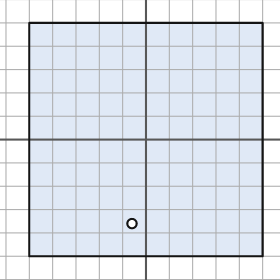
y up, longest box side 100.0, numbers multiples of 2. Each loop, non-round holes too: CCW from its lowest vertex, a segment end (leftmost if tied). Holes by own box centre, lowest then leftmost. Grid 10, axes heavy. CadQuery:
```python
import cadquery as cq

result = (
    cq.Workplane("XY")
    .moveTo(-50.0, -50.0)
    .lineTo(50.0, -50.0)
    .lineTo(50.0, 50.0)
    .lineTo(-50.0, 50.0)
    .close()
    .moveTo(-6.0, -36.0)
    .circle(2.0)
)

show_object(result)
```